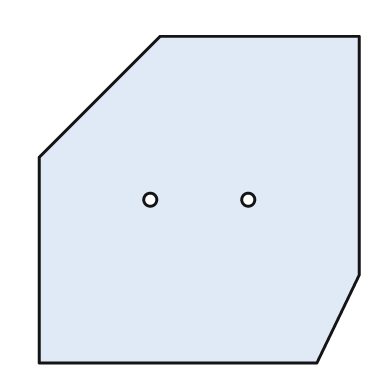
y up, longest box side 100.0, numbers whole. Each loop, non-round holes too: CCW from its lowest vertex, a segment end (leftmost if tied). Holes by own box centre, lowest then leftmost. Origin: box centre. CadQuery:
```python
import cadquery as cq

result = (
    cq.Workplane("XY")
    .moveTo(-49.0, -50.0)
    .lineTo(36.0, -50.0)
    .lineTo(49.0, -23.0)
    .lineTo(49.0, 50.0)
    .lineTo(-12.0, 50.0)
    .lineTo(-49.0, 13.0)
    .close()
    .moveTo(-15.0, 0.0)
    .circle(2.0)
    .moveTo(15.0, 0.0)
    .circle(2.0)
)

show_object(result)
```